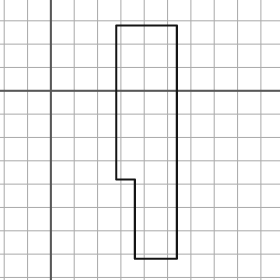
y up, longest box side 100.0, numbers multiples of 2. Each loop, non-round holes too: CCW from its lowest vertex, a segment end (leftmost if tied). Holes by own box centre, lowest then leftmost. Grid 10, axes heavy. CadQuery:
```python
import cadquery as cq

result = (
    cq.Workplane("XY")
    .moveTo(36.0, -72.0)
    .lineTo(54.0, -72.0)
    .lineTo(54.0, 28.0)
    .lineTo(28.0, 28.0)
    .lineTo(28.0, -38.0)
    .lineTo(36.0, -38.0)
    .close()
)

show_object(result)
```